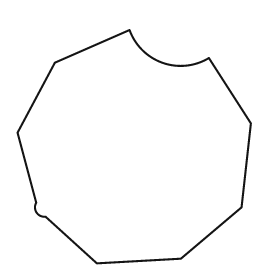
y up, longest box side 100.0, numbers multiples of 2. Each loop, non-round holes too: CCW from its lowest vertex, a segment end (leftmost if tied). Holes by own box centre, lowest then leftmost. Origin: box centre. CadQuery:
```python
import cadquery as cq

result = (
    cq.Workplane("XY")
    .moveTo(-16.0, -50.0)
    .lineTo(20.0, -48.0)
    .lineTo(46.0, -26.0)
    .lineTo(50.0, 10.0)
    .lineTo(32.0, 38.0)
    .threePointArc((12.0, 36.0), (-2.0, 50.0))
    .lineTo(-34.0, 36.0)
    .lineTo(-50.0, 6.0)
    .lineTo(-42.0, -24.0)
    .threePointArc((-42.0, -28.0), (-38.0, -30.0))
    .close()
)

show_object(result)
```